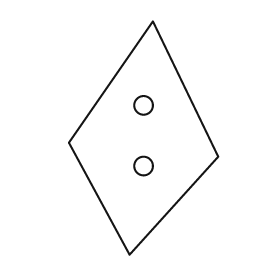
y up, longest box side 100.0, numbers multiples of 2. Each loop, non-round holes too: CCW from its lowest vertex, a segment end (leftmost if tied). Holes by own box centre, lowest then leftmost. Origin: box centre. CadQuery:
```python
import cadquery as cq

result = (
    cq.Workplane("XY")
    .moveTo(-6.0, -50.0)
    .lineTo(32.0, -8.0)
    .lineTo(4.0, 50.0)
    .lineTo(-32.0, -2.0)
    .close()
    .moveTo(0.0, -12.0)
    .circle(4.0)
    .moveTo(0.0, 14.0)
    .circle(4.0)
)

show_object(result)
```